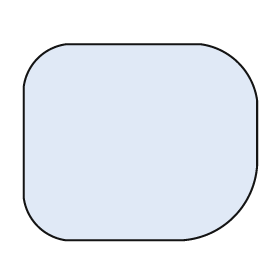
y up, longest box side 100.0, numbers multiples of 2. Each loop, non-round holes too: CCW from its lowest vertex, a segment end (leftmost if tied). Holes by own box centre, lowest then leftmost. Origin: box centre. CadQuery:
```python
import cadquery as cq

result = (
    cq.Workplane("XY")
    .moveTo(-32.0, -42.0)
    .lineTo(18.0, -42.0)
    .threePointArc((40.0, -32.0), (50.0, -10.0))
    .lineTo(50.0, 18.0)
    .threePointArc((42.0, 34.0), (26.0, 42.0))
    .lineTo(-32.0, 42.0)
    .threePointArc((-44.0, 36.0), (-50.0, 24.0))
    .lineTo(-50.0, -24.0)
    .threePointArc((-44.0, -36.0), (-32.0, -42.0))
    .close()
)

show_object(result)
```